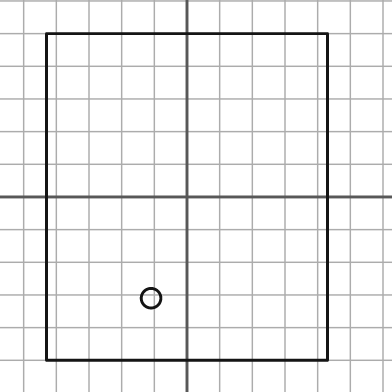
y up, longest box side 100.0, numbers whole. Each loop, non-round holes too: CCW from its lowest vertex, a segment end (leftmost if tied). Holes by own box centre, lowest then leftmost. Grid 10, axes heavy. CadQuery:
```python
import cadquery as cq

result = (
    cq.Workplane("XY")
    .moveTo(-43.0, -50.0)
    .lineTo(43.0, -50.0)
    .lineTo(43.0, 50.0)
    .lineTo(-43.0, 50.0)
    .close()
    .moveTo(-11.0, -31.0)
    .circle(3.0)
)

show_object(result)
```